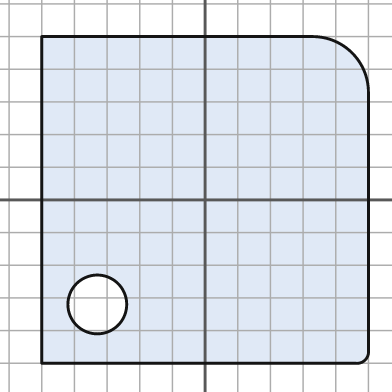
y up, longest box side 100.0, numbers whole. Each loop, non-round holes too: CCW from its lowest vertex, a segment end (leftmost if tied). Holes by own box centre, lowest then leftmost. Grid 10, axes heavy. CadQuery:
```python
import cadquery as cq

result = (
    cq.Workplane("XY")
    .moveTo(-50.0, -50.0)
    .lineTo(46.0, -50.0)
    .threePointArc((49.0, -49.0), (50.0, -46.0))
    .lineTo(50.0, 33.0)
    .threePointArc((45.0, 45.0), (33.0, 50.0))
    .lineTo(-50.0, 50.0)
    .close()
    .moveTo(-33.0, -32.0)
    .circle(9.0)
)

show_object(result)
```